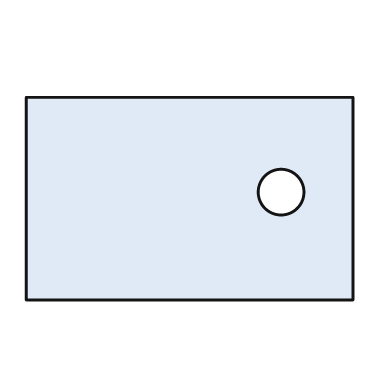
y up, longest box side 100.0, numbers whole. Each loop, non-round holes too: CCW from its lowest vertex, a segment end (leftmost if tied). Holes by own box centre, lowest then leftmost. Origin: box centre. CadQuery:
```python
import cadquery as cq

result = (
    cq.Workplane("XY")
    .moveTo(-50.0, -31.0)
    .lineTo(50.0, -31.0)
    .lineTo(50.0, 31.0)
    .lineTo(-50.0, 31.0)
    .close()
    .moveTo(28.0, 2.0)
    .circle(7.0)
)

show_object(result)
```